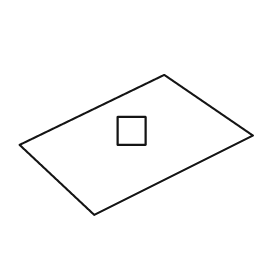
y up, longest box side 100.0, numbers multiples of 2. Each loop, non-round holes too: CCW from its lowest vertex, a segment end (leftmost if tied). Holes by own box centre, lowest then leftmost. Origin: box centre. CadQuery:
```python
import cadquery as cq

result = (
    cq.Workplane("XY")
    .moveTo(-18.0, -30.0)
    .lineTo(50.0, 4.0)
    .lineTo(12.0, 30.0)
    .lineTo(-50.0, 0.0)
    .close()
    .moveTo(-8.0, 0.0)
    .lineTo(4.0, 0.0)
    .lineTo(4.0, 12.0)
    .lineTo(-8.0, 12.0)
    .close()
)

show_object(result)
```